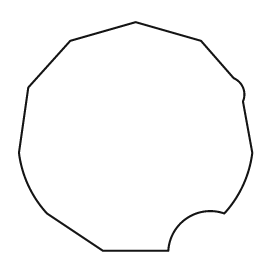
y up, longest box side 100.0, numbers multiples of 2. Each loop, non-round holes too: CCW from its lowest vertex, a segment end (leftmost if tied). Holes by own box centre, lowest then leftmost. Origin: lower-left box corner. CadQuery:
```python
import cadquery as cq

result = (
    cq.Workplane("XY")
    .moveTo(36.0, 0.0)
    .lineTo(64.0, 0.0)
    .threePointArc((72.0, 14.0), (88.0, 16.0))
    .threePointArc((96.0, 28.0), (100.0, 42.0))
    .lineTo(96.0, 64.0)
    .threePointArc((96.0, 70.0), (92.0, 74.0))
    .lineTo(78.0, 90.0)
    .lineTo(50.0, 98.0)
    .lineTo(22.0, 90.0)
    .lineTo(4.0, 70.0)
    .lineTo(0.0, 42.0)
    .threePointArc((4.0, 28.0), (12.0, 16.0))
    .close()
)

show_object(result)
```